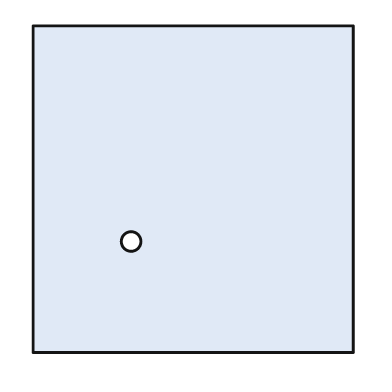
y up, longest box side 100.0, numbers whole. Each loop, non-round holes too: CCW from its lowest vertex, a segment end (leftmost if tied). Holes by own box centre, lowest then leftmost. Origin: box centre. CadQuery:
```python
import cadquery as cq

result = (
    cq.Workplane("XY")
    .moveTo(-49.0, -50.0)
    .lineTo(49.0, -50.0)
    .lineTo(49.0, 50.0)
    .lineTo(-49.0, 50.0)
    .close()
    .moveTo(-19.0, -16.0)
    .circle(3.0)
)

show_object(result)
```